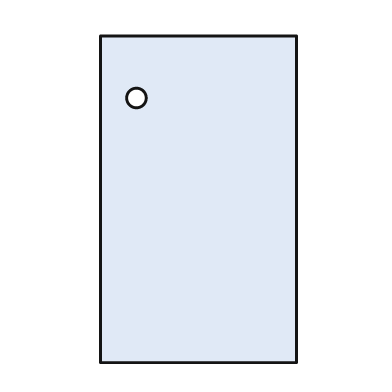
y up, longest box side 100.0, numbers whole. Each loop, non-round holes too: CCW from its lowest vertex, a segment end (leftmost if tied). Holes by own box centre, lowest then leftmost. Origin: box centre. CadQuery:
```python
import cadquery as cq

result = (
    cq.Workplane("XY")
    .moveTo(-30.0, -50.0)
    .lineTo(30.0, -50.0)
    .lineTo(30.0, 50.0)
    .lineTo(-30.0, 50.0)
    .close()
    .moveTo(-19.0, 31.0)
    .circle(3.0)
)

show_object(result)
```